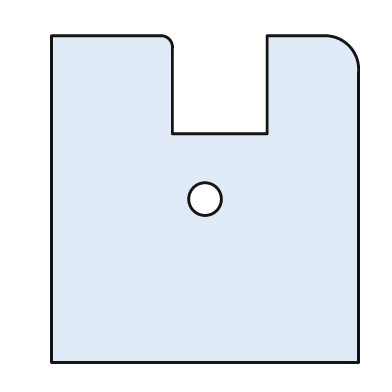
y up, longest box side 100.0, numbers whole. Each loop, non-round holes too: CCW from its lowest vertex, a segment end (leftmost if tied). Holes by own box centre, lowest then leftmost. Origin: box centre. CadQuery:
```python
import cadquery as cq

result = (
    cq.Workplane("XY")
    .moveTo(-47.0, -50.0)
    .lineTo(47.0, -50.0)
    .lineTo(47.0, 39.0)
    .threePointArc((44.0, 47.0), (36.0, 50.0))
    .lineTo(19.0, 50.0)
    .lineTo(19.0, 20.0)
    .lineTo(-10.0, 20.0)
    .lineTo(-10.0, 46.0)
    .threePointArc((-11.0, 49.0), (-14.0, 50.0))
    .lineTo(-47.0, 50.0)
    .close()
    .moveTo(0.0, 0.0)
    .circle(5.0)
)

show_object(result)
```